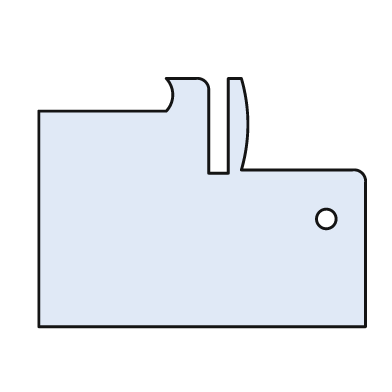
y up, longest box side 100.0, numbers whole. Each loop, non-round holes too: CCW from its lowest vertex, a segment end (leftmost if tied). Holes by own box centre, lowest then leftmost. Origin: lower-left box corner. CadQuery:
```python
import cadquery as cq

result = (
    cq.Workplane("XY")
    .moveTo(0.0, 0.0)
    .lineTo(100.0, 0.0)
    .lineTo(100.0, 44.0)
    .threePointArc((99.0, 47.0), (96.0, 48.0))
    .lineTo(62.0, 48.0)
    .threePointArc((64.0, 62.0), (62.0, 76.0))
    .lineTo(58.0, 76.0)
    .lineTo(58.0, 47.0)
    .lineTo(52.0, 47.0)
    .lineTo(52.0, 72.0)
    .threePointArc((51.0, 75.0), (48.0, 76.0))
    .lineTo(39.0, 76.0)
    .threePointArc((41.0, 71.0), (39.0, 66.0))
    .lineTo(0.0, 66.0)
    .close()
    .moveTo(88.0, 33.0)
    .circle(3.0)
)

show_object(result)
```